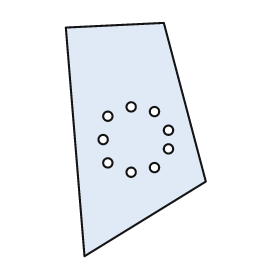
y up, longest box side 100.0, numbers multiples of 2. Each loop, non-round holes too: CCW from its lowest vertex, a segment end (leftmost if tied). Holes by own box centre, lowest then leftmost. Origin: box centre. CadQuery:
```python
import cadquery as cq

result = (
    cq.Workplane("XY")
    .moveTo(-22.0, -50.0)
    .lineTo(30.0, -18.0)
    .lineTo(12.0, 50.0)
    .lineTo(-30.0, 48.0)
    .close()
    .moveTo(-2.0, -14.0)
    .circle(2.0)
    .moveTo(8.0, -12.0)
    .circle(2.0)
    .moveTo(-12.0, -10.0)
    .circle(2.0)
    .moveTo(14.0, -4.0)
    .circle(2.0)
    .moveTo(-14.0, 0.0)
    .circle(2.0)
    .moveTo(14.0, 4.0)
    .circle(2.0)
    .moveTo(-12.0, 10.0)
    .circle(2.0)
    .moveTo(8.0, 12.0)
    .circle(2.0)
    .moveTo(-2.0, 14.0)
    .circle(2.0)
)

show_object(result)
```